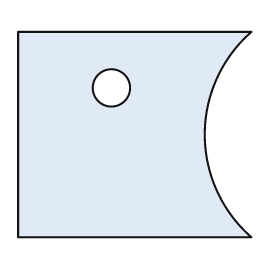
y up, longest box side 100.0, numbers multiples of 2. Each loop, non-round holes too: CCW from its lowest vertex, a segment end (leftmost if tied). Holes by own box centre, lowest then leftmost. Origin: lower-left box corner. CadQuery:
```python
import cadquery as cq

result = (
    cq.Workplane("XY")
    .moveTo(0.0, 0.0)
    .lineTo(100.0, 0.0)
    .threePointArc((80.0, 44.0), (100.0, 88.0))
    .lineTo(0.0, 88.0)
    .close()
    .moveTo(40.0, 64.0)
    .circle(8.0)
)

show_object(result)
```